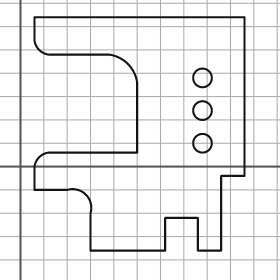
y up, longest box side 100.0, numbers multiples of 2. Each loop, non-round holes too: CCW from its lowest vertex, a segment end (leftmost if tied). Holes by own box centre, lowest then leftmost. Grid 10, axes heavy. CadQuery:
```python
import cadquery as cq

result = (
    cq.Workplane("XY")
    .moveTo(30.0, -36.0)
    .lineTo(62.0, -36.0)
    .lineTo(62.0, -22.0)
    .lineTo(76.0, -22.0)
    .lineTo(76.0, -36.0)
    .lineTo(86.0, -36.0)
    .lineTo(86.0, -4.0)
    .lineTo(96.0, -4.0)
    .lineTo(96.0, 64.0)
    .lineTo(6.0, 64.0)
    .lineTo(6.0, 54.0)
    .threePointArc((8.0, 50.0), (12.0, 48.0))
    .lineTo(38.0, 48.0)
    .threePointArc((46.0, 44.0), (50.0, 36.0))
    .lineTo(50.0, 6.0)
    .lineTo(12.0, 6.0)
    .threePointArc((8.0, 4.0), (6.0, 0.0))
    .lineTo(6.0, -10.0)
    .lineTo(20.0, -10.0)
    .threePointArc((28.0, -12.0), (30.0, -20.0))
    .close()
    .moveTo(78.0, 10.0)
    .circle(4.0)
    .moveTo(78.0, 24.0)
    .circle(4.0)
    .moveTo(78.0, 38.0)
    .circle(4.0)
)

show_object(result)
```